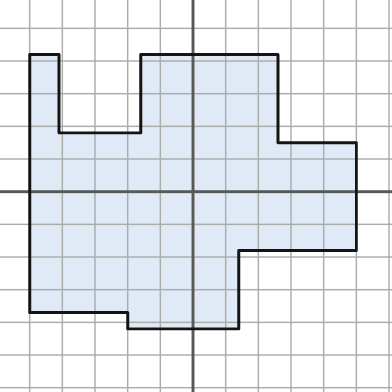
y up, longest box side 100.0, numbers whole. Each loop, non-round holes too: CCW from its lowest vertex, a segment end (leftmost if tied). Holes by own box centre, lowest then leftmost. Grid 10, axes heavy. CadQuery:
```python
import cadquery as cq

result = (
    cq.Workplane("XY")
    .moveTo(-20.0, -42.0)
    .lineTo(14.0, -42.0)
    .lineTo(14.0, -18.0)
    .lineTo(50.0, -18.0)
    .lineTo(50.0, 15.0)
    .lineTo(26.0, 15.0)
    .lineTo(26.0, 42.0)
    .lineTo(-16.0, 42.0)
    .lineTo(-16.0, 18.0)
    .lineTo(-41.0, 18.0)
    .lineTo(-41.0, 42.0)
    .lineTo(-50.0, 42.0)
    .lineTo(-50.0, -37.0)
    .lineTo(-20.0, -37.0)
    .close()
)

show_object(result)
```